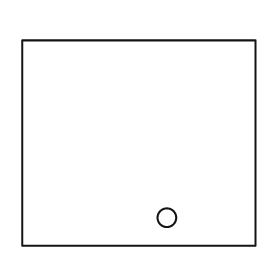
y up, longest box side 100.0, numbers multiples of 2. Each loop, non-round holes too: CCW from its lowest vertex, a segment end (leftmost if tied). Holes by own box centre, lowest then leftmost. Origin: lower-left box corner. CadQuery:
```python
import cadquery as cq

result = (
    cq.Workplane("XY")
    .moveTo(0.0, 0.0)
    .lineTo(100.0, 0.0)
    .lineTo(100.0, 88.0)
    .lineTo(0.0, 88.0)
    .close()
    .moveTo(62.0, 12.0)
    .circle(4.0)
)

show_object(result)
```